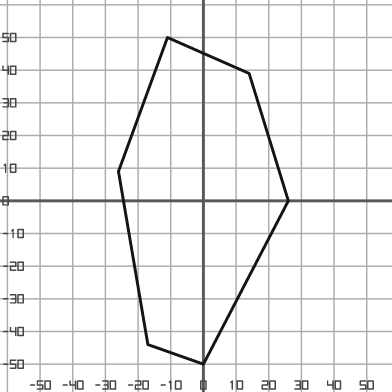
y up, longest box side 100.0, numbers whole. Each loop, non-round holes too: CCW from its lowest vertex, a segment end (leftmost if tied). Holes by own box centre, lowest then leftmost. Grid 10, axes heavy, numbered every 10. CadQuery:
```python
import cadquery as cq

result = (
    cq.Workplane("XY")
    .moveTo(0.0, -50.0)
    .lineTo(26.0, 0.0)
    .lineTo(14.0, 39.0)
    .lineTo(-11.0, 50.0)
    .lineTo(-26.0, 9.0)
    .lineTo(-17.0, -44.0)
    .close()
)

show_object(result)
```